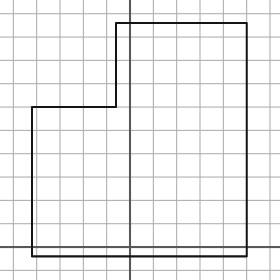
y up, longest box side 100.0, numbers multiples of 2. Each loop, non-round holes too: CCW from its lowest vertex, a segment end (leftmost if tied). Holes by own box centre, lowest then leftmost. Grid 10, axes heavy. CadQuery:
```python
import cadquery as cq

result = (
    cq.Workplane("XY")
    .moveTo(-42.0, -4.0)
    .lineTo(50.0, -4.0)
    .lineTo(50.0, 96.0)
    .lineTo(-6.0, 96.0)
    .lineTo(-6.0, 60.0)
    .lineTo(-42.0, 60.0)
    .close()
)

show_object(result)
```